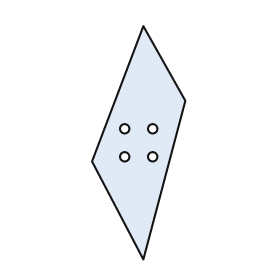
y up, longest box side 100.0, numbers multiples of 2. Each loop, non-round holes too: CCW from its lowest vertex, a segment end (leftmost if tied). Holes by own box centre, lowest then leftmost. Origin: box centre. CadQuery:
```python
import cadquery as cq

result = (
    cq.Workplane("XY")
    .moveTo(2.0, -50.0)
    .lineTo(20.0, 18.0)
    .lineTo(2.0, 50.0)
    .lineTo(-20.0, -8.0)
    .close()
    .moveTo(-6.0, -6.0)
    .circle(2.0)
    .moveTo(6.0, -6.0)
    .circle(2.0)
    .moveTo(-6.0, 6.0)
    .circle(2.0)
    .moveTo(6.0, 6.0)
    .circle(2.0)
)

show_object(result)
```